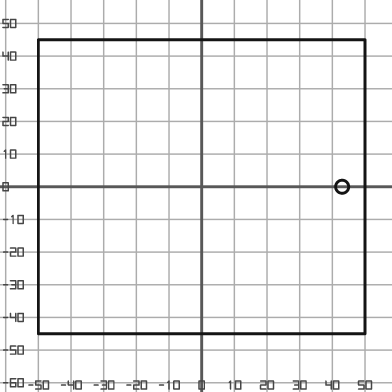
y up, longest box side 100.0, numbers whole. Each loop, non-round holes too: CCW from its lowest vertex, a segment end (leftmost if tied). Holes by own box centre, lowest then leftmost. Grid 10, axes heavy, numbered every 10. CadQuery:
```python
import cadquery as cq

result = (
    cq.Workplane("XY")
    .moveTo(-50.0, -45.0)
    .lineTo(50.0, -45.0)
    .lineTo(50.0, 45.0)
    .lineTo(-50.0, 45.0)
    .close()
    .moveTo(43.0, 0.0)
    .circle(2.0)
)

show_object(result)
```